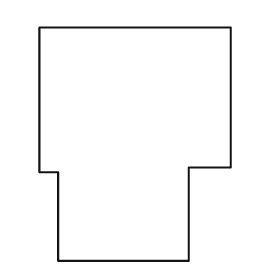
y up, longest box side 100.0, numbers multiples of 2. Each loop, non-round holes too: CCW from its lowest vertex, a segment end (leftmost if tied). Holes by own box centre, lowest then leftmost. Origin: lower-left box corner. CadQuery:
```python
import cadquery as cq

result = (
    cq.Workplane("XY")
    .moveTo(8.0, 0.0)
    .lineTo(64.0, 0.0)
    .lineTo(64.0, 40.0)
    .lineTo(82.0, 40.0)
    .lineTo(82.0, 100.0)
    .lineTo(0.0, 100.0)
    .lineTo(0.0, 38.0)
    .lineTo(8.0, 38.0)
    .close()
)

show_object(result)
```